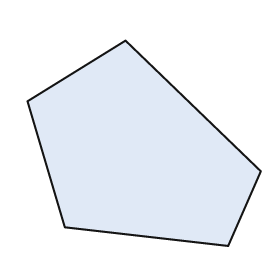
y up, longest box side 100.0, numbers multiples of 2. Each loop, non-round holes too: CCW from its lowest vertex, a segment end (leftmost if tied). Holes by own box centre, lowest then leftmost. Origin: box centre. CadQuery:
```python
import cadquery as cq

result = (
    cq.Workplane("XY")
    .moveTo(36.0, -44.0)
    .lineTo(50.0, -12.0)
    .lineTo(-8.0, 44.0)
    .lineTo(-50.0, 18.0)
    .lineTo(-34.0, -36.0)
    .close()
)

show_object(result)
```